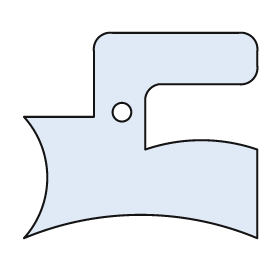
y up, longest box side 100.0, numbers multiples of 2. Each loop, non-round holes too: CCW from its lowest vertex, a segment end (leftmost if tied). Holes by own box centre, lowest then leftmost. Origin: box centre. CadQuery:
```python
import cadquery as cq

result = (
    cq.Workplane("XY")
    .moveTo(-50.0, -44.0)
    .threePointArc((0.0, -34.0), (50.0, -44.0))
    .lineTo(50.0, -6.0)
    .threePointArc((26.0, -2.0), (2.0, -6.0))
    .lineTo(2.0, 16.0)
    .threePointArc((4.0, 20.0), (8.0, 22.0))
    .lineTo(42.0, 22.0)
    .threePointArc((48.0, 24.0), (50.0, 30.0))
    .lineTo(50.0, 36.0)
    .threePointArc((48.0, 42.0), (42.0, 44.0))
    .lineTo(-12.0, 44.0)
    .threePointArc((-18.0, 42.0), (-20.0, 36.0))
    .lineTo(-20.0, 8.0)
    .lineTo(-50.0, 8.0)
    .threePointArc((-40.0, -18.0), (-50.0, -44.0))
    .close()
    .moveTo(-8.0, 10.0)
    .circle(4.0)
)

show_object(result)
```